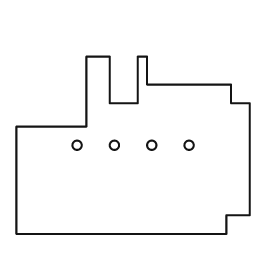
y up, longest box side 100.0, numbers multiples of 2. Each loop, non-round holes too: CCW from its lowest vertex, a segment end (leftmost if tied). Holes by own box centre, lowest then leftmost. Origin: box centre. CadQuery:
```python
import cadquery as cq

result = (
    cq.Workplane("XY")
    .moveTo(-50.0, -38.0)
    .lineTo(40.0, -38.0)
    .lineTo(40.0, -30.0)
    .lineTo(50.0, -30.0)
    .lineTo(50.0, 18.0)
    .lineTo(42.0, 18.0)
    .lineTo(42.0, 26.0)
    .lineTo(6.0, 26.0)
    .lineTo(6.0, 38.0)
    .lineTo(2.0, 38.0)
    .lineTo(2.0, 18.0)
    .lineTo(-10.0, 18.0)
    .lineTo(-10.0, 38.0)
    .lineTo(-20.0, 38.0)
    .lineTo(-20.0, 8.0)
    .lineTo(-50.0, 8.0)
    .close()
    .moveTo(-24.0, 0.0)
    .circle(2.0)
    .moveTo(-8.0, 0.0)
    .circle(2.0)
    .moveTo(8.0, 0.0)
    .circle(2.0)
    .moveTo(24.0, 0.0)
    .circle(2.0)
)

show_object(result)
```